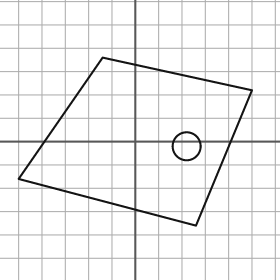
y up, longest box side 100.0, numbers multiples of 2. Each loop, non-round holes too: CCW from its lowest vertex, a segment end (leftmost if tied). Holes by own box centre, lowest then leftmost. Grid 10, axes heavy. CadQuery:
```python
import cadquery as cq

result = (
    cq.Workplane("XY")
    .moveTo(26.0, -36.0)
    .lineTo(50.0, 22.0)
    .lineTo(-14.0, 36.0)
    .lineTo(-50.0, -16.0)
    .close()
    .moveTo(22.0, -2.0)
    .circle(6.0)
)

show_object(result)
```